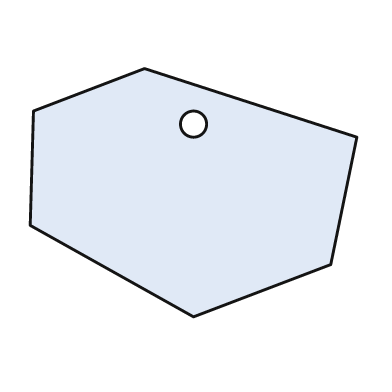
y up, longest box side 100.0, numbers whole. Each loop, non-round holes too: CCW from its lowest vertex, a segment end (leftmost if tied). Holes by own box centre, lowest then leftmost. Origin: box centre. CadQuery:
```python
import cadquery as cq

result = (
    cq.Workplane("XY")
    .moveTo(0.0, -38.0)
    .lineTo(42.0, -22.0)
    .lineTo(50.0, 17.0)
    .lineTo(-15.0, 38.0)
    .lineTo(-49.0, 25.0)
    .lineTo(-50.0, -10.0)
    .close()
    .moveTo(0.0, 21.0)
    .circle(4.0)
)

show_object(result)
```